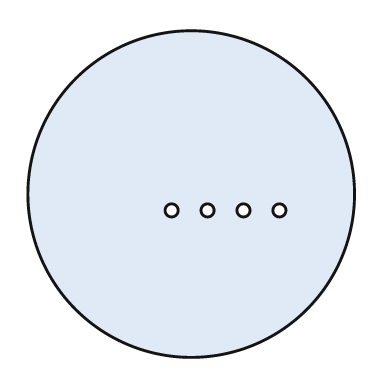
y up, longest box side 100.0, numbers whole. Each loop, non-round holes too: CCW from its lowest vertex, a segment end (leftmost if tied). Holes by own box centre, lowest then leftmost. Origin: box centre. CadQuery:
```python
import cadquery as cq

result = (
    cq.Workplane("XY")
    .moveTo(0.0, 0.0)
    .circle(50.0)
    .moveTo(-6.0, -5.0)
    .circle(2.0)
    .moveTo(5.0, -5.0)
    .circle(2.0)
    .moveTo(16.0, -5.0)
    .circle(2.0)
    .moveTo(27.0, -5.0)
    .circle(2.0)
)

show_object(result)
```